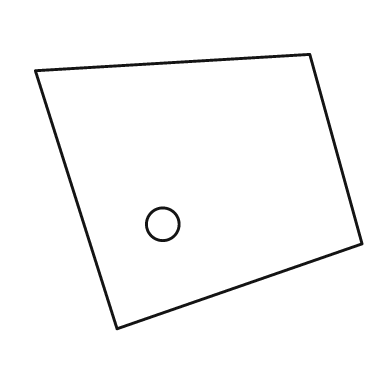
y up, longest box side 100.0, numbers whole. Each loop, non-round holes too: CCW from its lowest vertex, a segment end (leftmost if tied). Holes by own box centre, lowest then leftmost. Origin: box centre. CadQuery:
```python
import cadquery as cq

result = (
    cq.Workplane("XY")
    .moveTo(-25.0, -42.0)
    .lineTo(50.0, -16.0)
    .lineTo(34.0, 42.0)
    .lineTo(-50.0, 37.0)
    .close()
    .moveTo(-11.0, -10.0)
    .circle(5.0)
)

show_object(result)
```